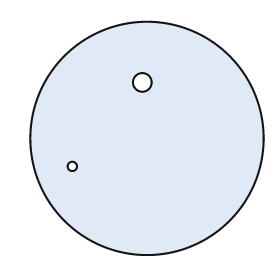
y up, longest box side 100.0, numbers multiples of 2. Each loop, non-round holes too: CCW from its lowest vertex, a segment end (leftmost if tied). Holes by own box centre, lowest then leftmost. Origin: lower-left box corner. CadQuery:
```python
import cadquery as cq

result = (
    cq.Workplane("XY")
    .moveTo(50.0, 50.0)
    .circle(50.0)
    .moveTo(18.0, 38.0)
    .circle(2.0)
    .moveTo(48.0, 74.0)
    .circle(4.0)
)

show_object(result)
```